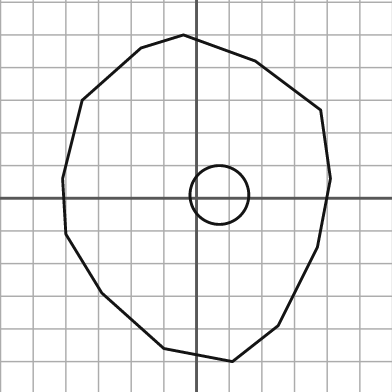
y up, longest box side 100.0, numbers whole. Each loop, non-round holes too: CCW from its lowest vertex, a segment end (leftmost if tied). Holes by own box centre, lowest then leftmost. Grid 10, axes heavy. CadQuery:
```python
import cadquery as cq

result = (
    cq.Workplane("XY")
    .moveTo(11.0, -50.0)
    .lineTo(25.0, -39.0)
    .lineTo(37.0, -15.0)
    .lineTo(41.0, 6.0)
    .lineTo(38.0, 27.0)
    .lineTo(18.0, 42.0)
    .lineTo(-4.0, 50.0)
    .lineTo(-17.0, 46.0)
    .lineTo(-35.0, 30.0)
    .lineTo(-41.0, 6.0)
    .lineTo(-40.0, -11.0)
    .lineTo(-29.0, -29.0)
    .lineTo(-10.0, -46.0)
    .close()
    .moveTo(7.0, 1.0)
    .circle(9.0)
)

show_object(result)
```